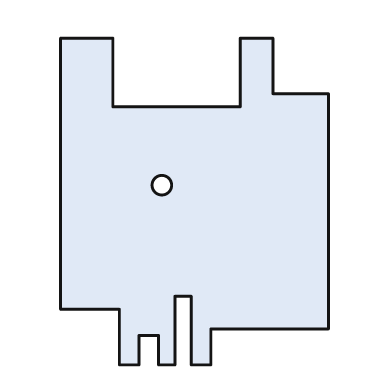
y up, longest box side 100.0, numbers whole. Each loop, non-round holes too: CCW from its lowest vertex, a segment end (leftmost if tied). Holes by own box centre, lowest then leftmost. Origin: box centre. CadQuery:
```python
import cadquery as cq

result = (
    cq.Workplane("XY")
    .moveTo(-23.0, -50.0)
    .lineTo(-17.0, -50.0)
    .lineTo(-17.0, -41.0)
    .lineTo(-11.0, -41.0)
    .lineTo(-11.0, -50.0)
    .lineTo(-6.0, -50.0)
    .lineTo(-6.0, -29.0)
    .lineTo(-1.0, -29.0)
    .lineTo(-1.0, -50.0)
    .lineTo(5.0, -50.0)
    .lineTo(5.0, -39.0)
    .lineTo(41.0, -39.0)
    .lineTo(41.0, 33.0)
    .lineTo(24.0, 33.0)
    .lineTo(24.0, 50.0)
    .lineTo(14.0, 50.0)
    .lineTo(14.0, 29.0)
    .lineTo(-25.0, 29.0)
    .lineTo(-25.0, 50.0)
    .lineTo(-41.0, 50.0)
    .lineTo(-41.0, -33.0)
    .lineTo(-23.0, -33.0)
    .close()
    .moveTo(-10.0, 5.0)
    .circle(3.0)
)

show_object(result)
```